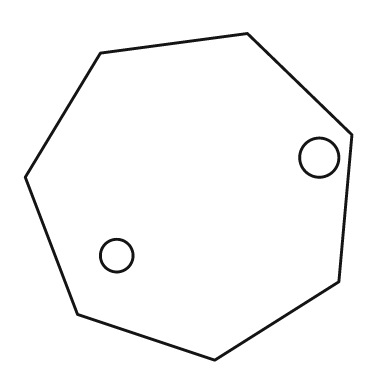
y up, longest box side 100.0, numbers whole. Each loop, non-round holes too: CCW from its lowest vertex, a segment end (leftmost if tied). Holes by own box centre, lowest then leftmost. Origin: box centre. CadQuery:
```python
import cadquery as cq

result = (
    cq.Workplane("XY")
    .moveTo(8.0, -50.0)
    .lineTo(46.0, -26.0)
    .lineTo(50.0, 19.0)
    .lineTo(18.0, 50.0)
    .lineTo(-27.0, 44.0)
    .lineTo(-50.0, 6.0)
    .lineTo(-34.0, -36.0)
    .close()
    .moveTo(-22.0, -18.0)
    .circle(5.0)
    .moveTo(40.0, 12.0)
    .circle(6.0)
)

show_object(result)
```